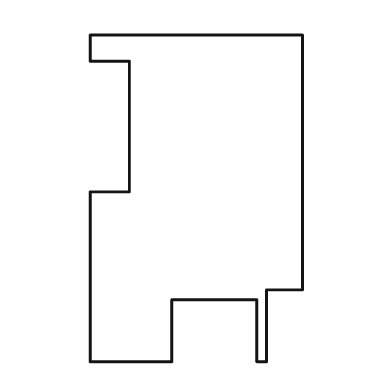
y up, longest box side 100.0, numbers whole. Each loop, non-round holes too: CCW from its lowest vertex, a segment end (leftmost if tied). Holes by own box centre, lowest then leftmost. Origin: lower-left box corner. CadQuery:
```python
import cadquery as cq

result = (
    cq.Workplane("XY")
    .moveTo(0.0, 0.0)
    .lineTo(25.0, 0.0)
    .lineTo(25.0, 19.0)
    .lineTo(51.0, 19.0)
    .lineTo(51.0, 0.0)
    .lineTo(54.0, 0.0)
    .lineTo(54.0, 22.0)
    .lineTo(65.0, 22.0)
    .lineTo(65.0, 100.0)
    .lineTo(0.0, 100.0)
    .lineTo(0.0, 92.0)
    .lineTo(12.0, 92.0)
    .lineTo(12.0, 52.0)
    .lineTo(0.0, 52.0)
    .close()
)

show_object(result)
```